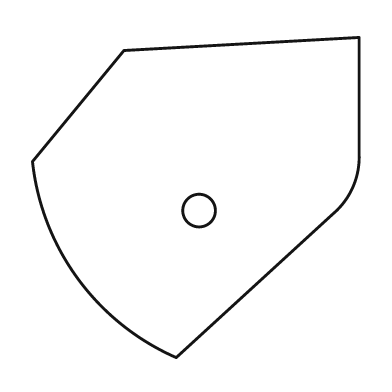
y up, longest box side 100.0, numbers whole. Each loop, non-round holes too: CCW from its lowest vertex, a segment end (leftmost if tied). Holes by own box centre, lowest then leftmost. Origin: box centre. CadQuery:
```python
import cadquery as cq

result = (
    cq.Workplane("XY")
    .moveTo(-6.0, -49.0)
    .lineTo(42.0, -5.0)
    .threePointArc((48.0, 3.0), (50.0, 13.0))
    .lineTo(50.0, 49.0)
    .lineTo(-22.0, 45.0)
    .lineTo(-50.0, 11.0)
    .threePointArc((-36.0, -25.0), (-6.0, -49.0))
    .close()
    .moveTo(1.0, -4.0)
    .circle(5.0)
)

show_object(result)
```